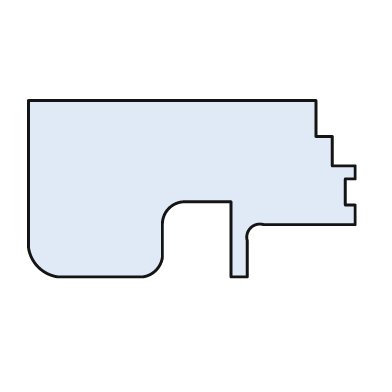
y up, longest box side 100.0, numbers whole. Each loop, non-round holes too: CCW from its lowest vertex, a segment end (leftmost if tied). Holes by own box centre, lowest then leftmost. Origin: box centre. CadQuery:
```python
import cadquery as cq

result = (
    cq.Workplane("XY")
    .moveTo(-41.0, -27.0)
    .lineTo(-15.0, -27.0)
    .threePointArc((-11.0, -25.0), (-9.0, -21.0))
    .lineTo(-9.0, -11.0)
    .threePointArc((-7.0, -6.0), (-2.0, -4.0))
    .lineTo(12.0, -4.0)
    .lineTo(12.0, -27.0)
    .lineTo(17.0, -27.0)
    .lineTo(17.0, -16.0)
    .threePointArc((18.0, -12.0), (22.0, -11.0))
    .lineTo(50.0, -11.0)
    .lineTo(50.0, -5.0)
    .lineTo(47.0, -5.0)
    .lineTo(47.0, 3.0)
    .lineTo(50.0, 3.0)
    .lineTo(50.0, 7.0)
    .lineTo(43.0, 7.0)
    .lineTo(43.0, 16.0)
    .lineTo(38.0, 16.0)
    .lineTo(38.0, 27.0)
    .lineTo(-50.0, 27.0)
    .lineTo(-50.0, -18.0)
    .threePointArc((-47.0, -24.0), (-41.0, -27.0))
    .close()
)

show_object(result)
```